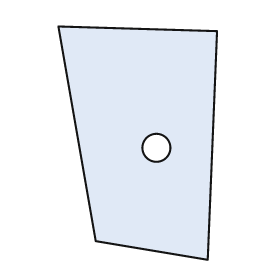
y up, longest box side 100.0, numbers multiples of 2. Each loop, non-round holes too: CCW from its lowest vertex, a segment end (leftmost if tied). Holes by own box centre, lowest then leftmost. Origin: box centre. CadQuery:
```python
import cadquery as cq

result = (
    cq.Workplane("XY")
    .moveTo(30.0, -50.0)
    .lineTo(34.0, 48.0)
    .lineTo(-34.0, 50.0)
    .lineTo(-18.0, -42.0)
    .close()
    .moveTo(8.0, -2.0)
    .circle(6.0)
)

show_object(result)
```